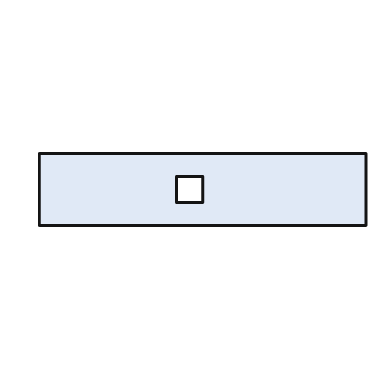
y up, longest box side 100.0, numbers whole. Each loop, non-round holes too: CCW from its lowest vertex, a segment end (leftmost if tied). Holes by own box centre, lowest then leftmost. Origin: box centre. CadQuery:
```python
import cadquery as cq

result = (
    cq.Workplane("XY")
    .moveTo(-50.0, -11.0)
    .lineTo(50.0, -11.0)
    .lineTo(50.0, 11.0)
    .lineTo(-50.0, 11.0)
    .close()
    .moveTo(-8.0, -4.0)
    .lineTo(0.0, -4.0)
    .lineTo(0.0, 4.0)
    .lineTo(-8.0, 4.0)
    .close()
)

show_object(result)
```